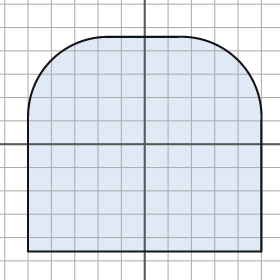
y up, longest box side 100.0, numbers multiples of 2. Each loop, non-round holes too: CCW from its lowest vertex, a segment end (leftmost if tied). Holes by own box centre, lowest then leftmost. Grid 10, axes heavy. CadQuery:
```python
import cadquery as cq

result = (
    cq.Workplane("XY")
    .moveTo(-50.0, -46.0)
    .lineTo(50.0, -46.0)
    .lineTo(50.0, 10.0)
    .threePointArc((40.0, 36.0), (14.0, 46.0))
    .lineTo(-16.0, 46.0)
    .threePointArc((-40.0, 36.0), (-50.0, 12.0))
    .close()
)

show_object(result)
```